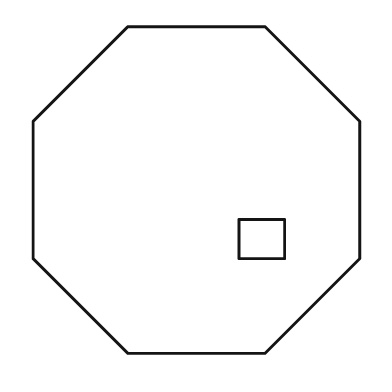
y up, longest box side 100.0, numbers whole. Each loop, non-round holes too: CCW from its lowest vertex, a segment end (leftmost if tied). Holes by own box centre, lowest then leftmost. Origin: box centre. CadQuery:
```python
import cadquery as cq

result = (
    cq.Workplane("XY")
    .moveTo(-21.0, -50.0)
    .lineTo(21.0, -50.0)
    .lineTo(50.0, -21.0)
    .lineTo(50.0, 21.0)
    .lineTo(21.0, 50.0)
    .lineTo(-21.0, 50.0)
    .lineTo(-50.0, 21.0)
    .lineTo(-50.0, -21.0)
    .close()
    .moveTo(13.0, -21.0)
    .lineTo(27.0, -21.0)
    .lineTo(27.0, -9.0)
    .lineTo(13.0, -9.0)
    .close()
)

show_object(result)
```